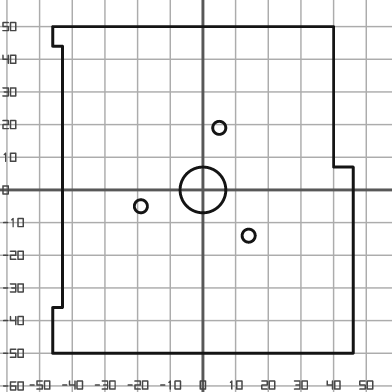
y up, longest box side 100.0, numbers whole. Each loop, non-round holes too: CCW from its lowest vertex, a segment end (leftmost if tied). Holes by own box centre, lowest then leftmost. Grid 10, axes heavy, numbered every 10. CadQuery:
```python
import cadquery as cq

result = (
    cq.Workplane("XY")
    .moveTo(-46.0, -50.0)
    .lineTo(46.0, -50.0)
    .lineTo(46.0, 7.0)
    .lineTo(40.0, 7.0)
    .lineTo(40.0, 50.0)
    .lineTo(-46.0, 50.0)
    .lineTo(-46.0, 44.0)
    .lineTo(-43.0, 44.0)
    .lineTo(-43.0, -36.0)
    .lineTo(-46.0, -36.0)
    .close()
    .moveTo(14.0, -14.0)
    .circle(2.0)
    .moveTo(-19.0, -5.0)
    .circle(2.0)
    .moveTo(0.0, 0.0)
    .circle(7.0)
    .moveTo(5.0, 19.0)
    .circle(2.0)
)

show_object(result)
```